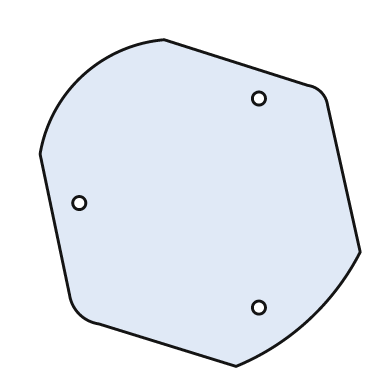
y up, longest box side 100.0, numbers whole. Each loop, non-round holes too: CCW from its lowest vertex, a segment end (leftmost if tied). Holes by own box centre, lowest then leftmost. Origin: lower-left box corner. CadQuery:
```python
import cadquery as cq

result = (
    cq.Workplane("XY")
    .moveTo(60.0, 0.0)
    .threePointArc((82.0, 14.0), (98.0, 35.0))
    .lineTo(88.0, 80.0)
    .threePointArc((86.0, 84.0), (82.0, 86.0))
    .lineTo(38.0, 100.0)
    .threePointArc((13.0, 89.0), (0.0, 65.0))
    .lineTo(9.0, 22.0)
    .threePointArc((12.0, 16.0), (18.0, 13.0))
    .close()
    .moveTo(67.0, 18.0)
    .circle(2.0)
    .moveTo(12.0, 50.0)
    .circle(2.0)
    .moveTo(67.0, 82.0)
    .circle(2.0)
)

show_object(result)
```